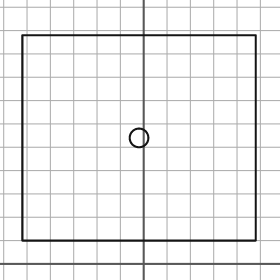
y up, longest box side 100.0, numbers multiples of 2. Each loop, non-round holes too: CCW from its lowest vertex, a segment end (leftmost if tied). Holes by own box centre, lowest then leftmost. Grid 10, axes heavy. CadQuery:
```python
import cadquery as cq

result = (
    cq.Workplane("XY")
    .moveTo(-52.0, 10.0)
    .lineTo(48.0, 10.0)
    .lineTo(48.0, 98.0)
    .lineTo(-52.0, 98.0)
    .close()
    .moveTo(-2.0, 54.0)
    .circle(4.0)
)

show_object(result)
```